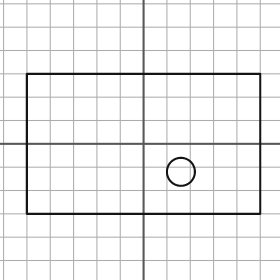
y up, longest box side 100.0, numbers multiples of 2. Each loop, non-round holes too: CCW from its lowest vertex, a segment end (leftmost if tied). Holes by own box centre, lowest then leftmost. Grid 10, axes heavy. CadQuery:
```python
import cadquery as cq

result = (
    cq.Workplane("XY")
    .moveTo(-50.0, -30.0)
    .lineTo(50.0, -30.0)
    .lineTo(50.0, 30.0)
    .lineTo(-50.0, 30.0)
    .close()
    .moveTo(16.0, -12.0)
    .circle(6.0)
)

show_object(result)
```